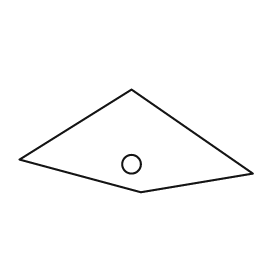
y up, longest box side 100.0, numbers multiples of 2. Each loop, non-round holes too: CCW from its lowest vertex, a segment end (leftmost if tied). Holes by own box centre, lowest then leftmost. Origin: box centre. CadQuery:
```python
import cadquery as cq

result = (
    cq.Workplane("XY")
    .moveTo(2.0, -22.0)
    .lineTo(50.0, -14.0)
    .lineTo(-2.0, 22.0)
    .lineTo(-50.0, -8.0)
    .close()
    .moveTo(-2.0, -10.0)
    .circle(4.0)
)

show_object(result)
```